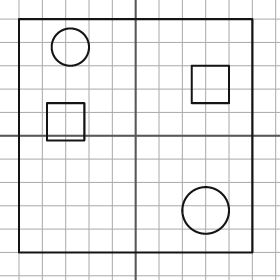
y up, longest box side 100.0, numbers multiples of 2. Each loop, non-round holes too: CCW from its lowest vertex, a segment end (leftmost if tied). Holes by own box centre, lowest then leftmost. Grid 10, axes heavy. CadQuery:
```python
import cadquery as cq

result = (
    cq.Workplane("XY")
    .moveTo(-50.0, -50.0)
    .lineTo(50.0, -50.0)
    .lineTo(50.0, 50.0)
    .lineTo(-50.0, 50.0)
    .close()
    .moveTo(30.0, -32.0)
    .circle(10.0)
    .moveTo(-38.0, -2.0)
    .lineTo(-22.0, -2.0)
    .lineTo(-22.0, 14.0)
    .lineTo(-38.0, 14.0)
    .close()
    .moveTo(24.0, 14.0)
    .lineTo(40.0, 14.0)
    .lineTo(40.0, 30.0)
    .lineTo(24.0, 30.0)
    .close()
    .moveTo(-28.0, 38.0)
    .circle(8.0)
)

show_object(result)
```